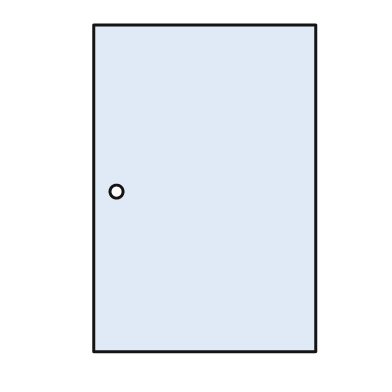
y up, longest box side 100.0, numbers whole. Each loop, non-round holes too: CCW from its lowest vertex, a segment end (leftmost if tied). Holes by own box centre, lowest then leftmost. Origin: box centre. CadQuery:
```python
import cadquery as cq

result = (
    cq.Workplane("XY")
    .moveTo(-34.0, -50.0)
    .lineTo(34.0, -50.0)
    .lineTo(34.0, 50.0)
    .lineTo(-34.0, 50.0)
    .close()
    .moveTo(-27.0, -1.0)
    .circle(2.0)
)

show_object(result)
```